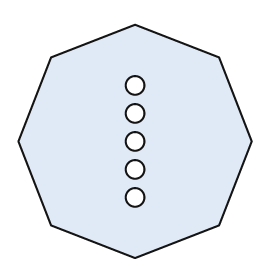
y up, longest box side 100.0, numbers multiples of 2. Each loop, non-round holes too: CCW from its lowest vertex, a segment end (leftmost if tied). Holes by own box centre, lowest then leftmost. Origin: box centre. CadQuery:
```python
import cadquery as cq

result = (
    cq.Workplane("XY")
    .moveTo(0.0, -50.0)
    .lineTo(36.0, -36.0)
    .lineTo(50.0, 0.0)
    .lineTo(36.0, 36.0)
    .lineTo(0.0, 50.0)
    .lineTo(-36.0, 36.0)
    .lineTo(-50.0, 0.0)
    .lineTo(-36.0, -36.0)
    .close()
    .moveTo(0.0, -24.0)
    .circle(4.0)
    .moveTo(0.0, -12.0)
    .circle(4.0)
    .moveTo(0.0, 0.0)
    .circle(4.0)
    .moveTo(0.0, 12.0)
    .circle(4.0)
    .moveTo(0.0, 24.0)
    .circle(4.0)
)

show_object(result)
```